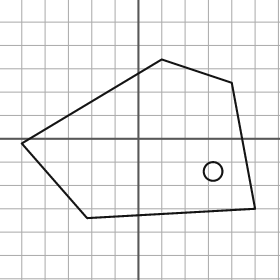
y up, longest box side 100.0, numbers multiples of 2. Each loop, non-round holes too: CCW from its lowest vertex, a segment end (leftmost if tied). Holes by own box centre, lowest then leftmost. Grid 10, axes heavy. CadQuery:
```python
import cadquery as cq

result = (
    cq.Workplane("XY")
    .moveTo(-22.0, -34.0)
    .lineTo(50.0, -30.0)
    .lineTo(40.0, 24.0)
    .lineTo(10.0, 34.0)
    .lineTo(-50.0, -2.0)
    .close()
    .moveTo(32.0, -14.0)
    .circle(4.0)
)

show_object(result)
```